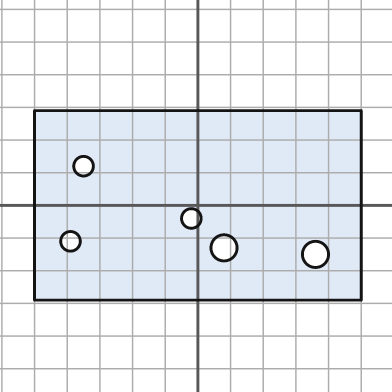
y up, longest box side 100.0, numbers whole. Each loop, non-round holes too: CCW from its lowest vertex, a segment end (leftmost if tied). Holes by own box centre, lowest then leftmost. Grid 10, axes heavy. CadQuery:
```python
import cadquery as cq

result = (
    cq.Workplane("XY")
    .moveTo(-50.0, -29.0)
    .lineTo(50.0, -29.0)
    .lineTo(50.0, 29.0)
    .lineTo(-50.0, 29.0)
    .close()
    .moveTo(36.0, -15.0)
    .circle(4.0)
    .moveTo(8.0, -13.0)
    .circle(4.0)
    .moveTo(-39.0, -11.0)
    .circle(3.0)
    .moveTo(-2.0, -4.0)
    .circle(3.0)
    .moveTo(-35.0, 12.0)
    .circle(3.0)
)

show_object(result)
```